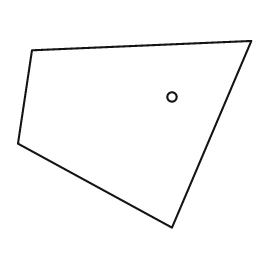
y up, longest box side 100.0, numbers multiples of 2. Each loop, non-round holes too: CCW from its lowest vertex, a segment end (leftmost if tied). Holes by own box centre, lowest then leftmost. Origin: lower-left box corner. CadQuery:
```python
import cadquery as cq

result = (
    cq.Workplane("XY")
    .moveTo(66.0, 0.0)
    .lineTo(100.0, 80.0)
    .lineTo(6.0, 76.0)
    .lineTo(0.0, 36.0)
    .close()
    .moveTo(66.0, 56.0)
    .circle(2.0)
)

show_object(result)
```